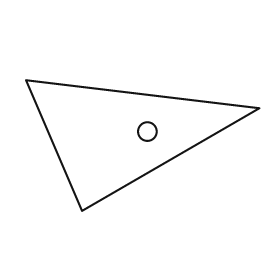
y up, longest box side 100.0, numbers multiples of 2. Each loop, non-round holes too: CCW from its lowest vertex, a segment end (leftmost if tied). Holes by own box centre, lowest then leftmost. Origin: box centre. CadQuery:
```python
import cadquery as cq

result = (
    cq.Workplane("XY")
    .moveTo(-26.0, -28.0)
    .lineTo(50.0, 16.0)
    .lineTo(-50.0, 28.0)
    .close()
    .moveTo(2.0, 6.0)
    .circle(4.0)
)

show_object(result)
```